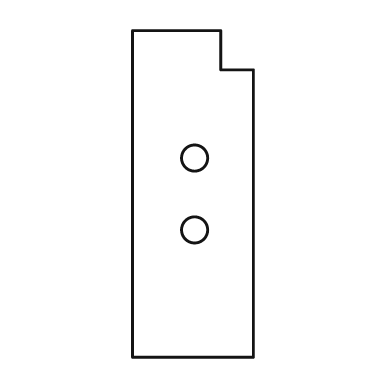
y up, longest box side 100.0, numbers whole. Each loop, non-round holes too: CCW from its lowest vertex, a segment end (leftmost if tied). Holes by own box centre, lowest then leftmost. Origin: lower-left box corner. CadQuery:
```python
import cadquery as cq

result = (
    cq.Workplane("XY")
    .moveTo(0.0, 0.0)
    .lineTo(37.0, 0.0)
    .lineTo(37.0, 88.0)
    .lineTo(27.0, 88.0)
    .lineTo(27.0, 100.0)
    .lineTo(0.0, 100.0)
    .close()
    .moveTo(19.0, 39.0)
    .circle(4.0)
    .moveTo(19.0, 61.0)
    .circle(4.0)
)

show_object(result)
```